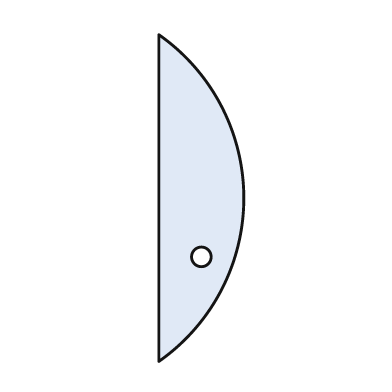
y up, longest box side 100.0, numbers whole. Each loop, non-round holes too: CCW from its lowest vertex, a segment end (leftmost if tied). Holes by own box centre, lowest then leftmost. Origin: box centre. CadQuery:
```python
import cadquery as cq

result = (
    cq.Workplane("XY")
    .moveTo(-13.0, -50.0)
    .threePointArc((13.0, 0.0), (-13.0, 50.0))
    .close()
    .moveTo(0.0, -18.0)
    .circle(3.0)
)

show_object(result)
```